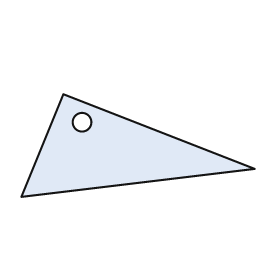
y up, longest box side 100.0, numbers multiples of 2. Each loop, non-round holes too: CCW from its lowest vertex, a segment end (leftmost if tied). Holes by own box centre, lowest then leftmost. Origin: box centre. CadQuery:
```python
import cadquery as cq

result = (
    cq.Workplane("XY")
    .moveTo(-50.0, -22.0)
    .lineTo(50.0, -10.0)
    .lineTo(-32.0, 22.0)
    .close()
    .moveTo(-24.0, 10.0)
    .circle(4.0)
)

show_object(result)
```